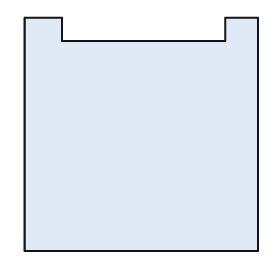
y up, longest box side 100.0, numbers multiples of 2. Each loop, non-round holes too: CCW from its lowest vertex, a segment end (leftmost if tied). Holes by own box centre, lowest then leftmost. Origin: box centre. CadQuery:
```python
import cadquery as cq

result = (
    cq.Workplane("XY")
    .moveTo(-50.0, -50.0)
    .lineTo(50.0, -50.0)
    .lineTo(50.0, 50.0)
    .lineTo(36.0, 50.0)
    .lineTo(36.0, 40.0)
    .lineTo(-34.0, 40.0)
    .lineTo(-34.0, 50.0)
    .lineTo(-50.0, 50.0)
    .close()
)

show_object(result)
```